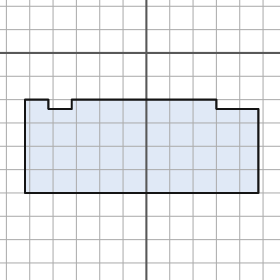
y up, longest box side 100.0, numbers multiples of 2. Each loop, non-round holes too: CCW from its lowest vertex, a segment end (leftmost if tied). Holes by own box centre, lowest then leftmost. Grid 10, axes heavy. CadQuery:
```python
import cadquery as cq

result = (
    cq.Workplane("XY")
    .moveTo(-52.0, -60.0)
    .lineTo(48.0, -60.0)
    .lineTo(48.0, -24.0)
    .lineTo(30.0, -24.0)
    .lineTo(30.0, -20.0)
    .lineTo(-32.0, -20.0)
    .lineTo(-32.0, -24.0)
    .lineTo(-42.0, -24.0)
    .lineTo(-42.0, -20.0)
    .lineTo(-52.0, -20.0)
    .close()
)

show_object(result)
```